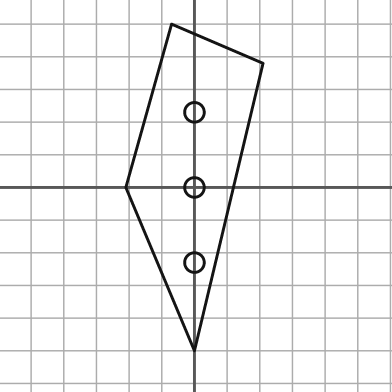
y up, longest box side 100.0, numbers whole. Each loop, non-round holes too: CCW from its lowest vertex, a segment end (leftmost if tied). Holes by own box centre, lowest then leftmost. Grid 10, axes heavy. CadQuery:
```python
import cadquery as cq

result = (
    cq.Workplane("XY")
    .moveTo(0.0, -50.0)
    .lineTo(21.0, 38.0)
    .lineTo(-7.0, 50.0)
    .lineTo(-21.0, 0.0)
    .close()
    .moveTo(0.0, -23.0)
    .circle(3.0)
    .moveTo(0.0, 0.0)
    .circle(3.0)
    .moveTo(0.0, 23.0)
    .circle(3.0)
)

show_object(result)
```